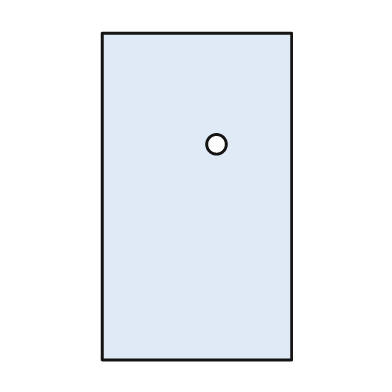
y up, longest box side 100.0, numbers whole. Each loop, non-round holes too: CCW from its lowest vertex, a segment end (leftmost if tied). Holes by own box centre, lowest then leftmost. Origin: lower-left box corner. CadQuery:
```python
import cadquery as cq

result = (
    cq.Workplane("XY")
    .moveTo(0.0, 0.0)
    .lineTo(58.0, 0.0)
    .lineTo(58.0, 100.0)
    .lineTo(0.0, 100.0)
    .close()
    .moveTo(35.0, 66.0)
    .circle(3.0)
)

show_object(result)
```